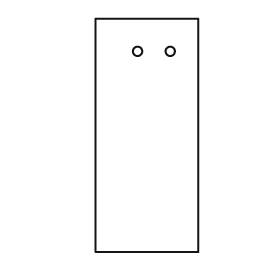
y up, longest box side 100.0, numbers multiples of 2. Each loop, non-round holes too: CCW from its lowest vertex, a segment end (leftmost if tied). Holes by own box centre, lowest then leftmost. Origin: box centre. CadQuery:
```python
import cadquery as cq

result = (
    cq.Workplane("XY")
    .moveTo(-22.0, -50.0)
    .lineTo(22.0, -50.0)
    .lineTo(22.0, 50.0)
    .lineTo(-22.0, 50.0)
    .close()
    .moveTo(-4.0, 36.0)
    .circle(2.0)
    .moveTo(10.0, 36.0)
    .circle(2.0)
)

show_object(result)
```